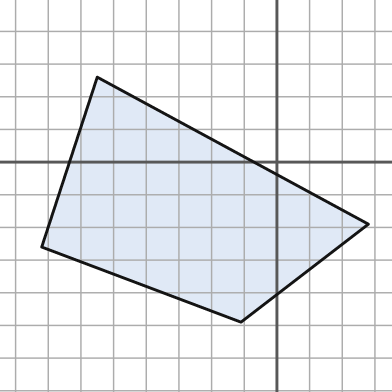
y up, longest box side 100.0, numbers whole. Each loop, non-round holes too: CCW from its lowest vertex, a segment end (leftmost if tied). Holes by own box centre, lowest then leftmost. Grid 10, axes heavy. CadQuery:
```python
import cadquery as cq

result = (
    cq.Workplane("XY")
    .moveTo(-11.0, -49.0)
    .lineTo(28.0, -19.0)
    .lineTo(-55.0, 26.0)
    .lineTo(-72.0, -26.0)
    .close()
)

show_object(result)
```